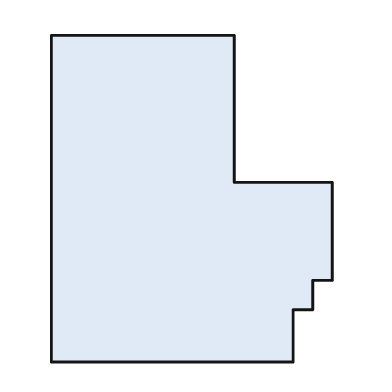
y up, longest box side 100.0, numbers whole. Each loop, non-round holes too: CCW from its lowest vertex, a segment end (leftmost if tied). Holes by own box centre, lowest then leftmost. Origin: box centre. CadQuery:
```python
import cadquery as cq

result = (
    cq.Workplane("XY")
    .moveTo(-43.0, -50.0)
    .lineTo(31.0, -50.0)
    .lineTo(31.0, -34.0)
    .lineTo(37.0, -34.0)
    .lineTo(37.0, -25.0)
    .lineTo(43.0, -25.0)
    .lineTo(43.0, 5.0)
    .lineTo(13.0, 5.0)
    .lineTo(13.0, 50.0)
    .lineTo(-43.0, 50.0)
    .close()
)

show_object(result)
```